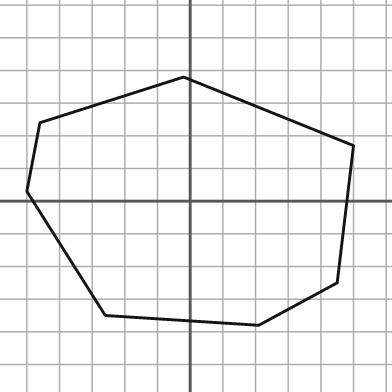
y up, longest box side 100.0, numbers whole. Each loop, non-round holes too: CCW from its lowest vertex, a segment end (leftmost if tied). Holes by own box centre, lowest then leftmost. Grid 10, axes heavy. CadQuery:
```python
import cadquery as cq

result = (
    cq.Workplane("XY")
    .moveTo(21.0, -38.0)
    .lineTo(45.0, -25.0)
    .lineTo(50.0, 17.0)
    .lineTo(-2.0, 38.0)
    .lineTo(-46.0, 24.0)
    .lineTo(-50.0, 3.0)
    .lineTo(-26.0, -35.0)
    .close()
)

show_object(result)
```